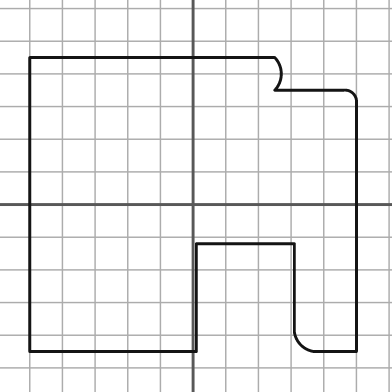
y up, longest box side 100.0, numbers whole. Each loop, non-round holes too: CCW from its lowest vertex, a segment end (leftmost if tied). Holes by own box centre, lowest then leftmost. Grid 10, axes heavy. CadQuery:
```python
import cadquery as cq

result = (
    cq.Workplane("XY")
    .moveTo(-50.0, -45.0)
    .lineTo(1.0, -45.0)
    .lineTo(1.0, -12.0)
    .lineTo(31.0, -12.0)
    .lineTo(31.0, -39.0)
    .threePointArc((33.0, -43.0), (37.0, -45.0))
    .lineTo(50.0, -45.0)
    .lineTo(50.0, 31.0)
    .threePointArc((49.0, 34.0), (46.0, 35.0))
    .lineTo(25.0, 35.0)
    .threePointArc((27.0, 40.0), (25.0, 45.0))
    .lineTo(-50.0, 45.0)
    .close()
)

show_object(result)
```